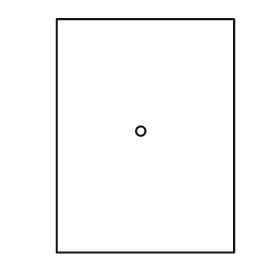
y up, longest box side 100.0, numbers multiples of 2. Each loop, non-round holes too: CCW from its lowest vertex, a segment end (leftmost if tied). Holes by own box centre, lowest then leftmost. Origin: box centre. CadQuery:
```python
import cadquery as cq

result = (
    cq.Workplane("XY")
    .moveTo(-38.0, -50.0)
    .lineTo(38.0, -50.0)
    .lineTo(38.0, 50.0)
    .lineTo(-38.0, 50.0)
    .close()
    .moveTo(-2.0, 2.0)
    .circle(2.0)
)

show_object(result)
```